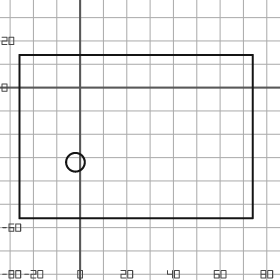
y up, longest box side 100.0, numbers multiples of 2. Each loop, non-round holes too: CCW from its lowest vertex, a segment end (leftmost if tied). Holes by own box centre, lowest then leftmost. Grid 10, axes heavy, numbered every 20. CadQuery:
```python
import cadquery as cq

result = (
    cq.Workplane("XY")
    .moveTo(-26.0, -56.0)
    .lineTo(74.0, -56.0)
    .lineTo(74.0, 14.0)
    .lineTo(-26.0, 14.0)
    .close()
    .moveTo(-2.0, -32.0)
    .circle(4.0)
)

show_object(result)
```